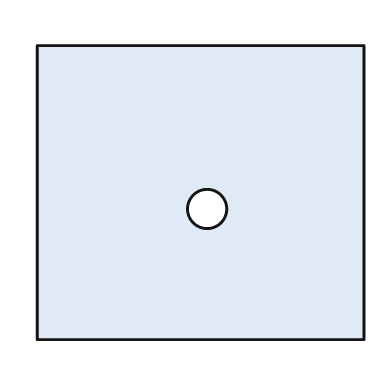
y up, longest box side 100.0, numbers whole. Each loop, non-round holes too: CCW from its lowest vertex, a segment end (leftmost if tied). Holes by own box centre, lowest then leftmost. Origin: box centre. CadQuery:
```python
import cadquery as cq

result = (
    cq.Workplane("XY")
    .moveTo(-50.0, -45.0)
    .lineTo(50.0, -45.0)
    .lineTo(50.0, 45.0)
    .lineTo(-50.0, 45.0)
    .close()
    .moveTo(2.0, -5.0)
    .circle(6.0)
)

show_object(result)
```